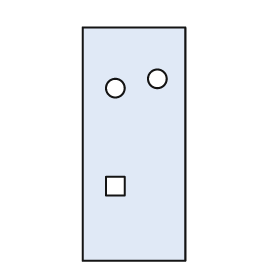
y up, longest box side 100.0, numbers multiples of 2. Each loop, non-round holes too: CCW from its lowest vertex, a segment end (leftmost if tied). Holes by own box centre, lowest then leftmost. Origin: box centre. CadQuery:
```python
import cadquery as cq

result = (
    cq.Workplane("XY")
    .moveTo(-22.0, -50.0)
    .lineTo(22.0, -50.0)
    .lineTo(22.0, 50.0)
    .lineTo(-22.0, 50.0)
    .close()
    .moveTo(-12.0, -22.0)
    .lineTo(-4.0, -22.0)
    .lineTo(-4.0, -14.0)
    .lineTo(-12.0, -14.0)
    .close()
    .moveTo(-8.0, 24.0)
    .circle(4.0)
    .moveTo(10.0, 28.0)
    .circle(4.0)
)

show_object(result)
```